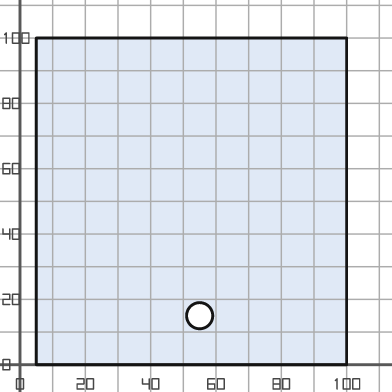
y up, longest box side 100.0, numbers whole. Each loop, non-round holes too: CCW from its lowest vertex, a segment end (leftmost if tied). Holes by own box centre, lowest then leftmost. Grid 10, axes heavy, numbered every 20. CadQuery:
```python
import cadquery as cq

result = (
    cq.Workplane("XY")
    .moveTo(5.0, 0.0)
    .lineTo(100.0, 0.0)
    .lineTo(100.0, 100.0)
    .lineTo(5.0, 100.0)
    .close()
    .moveTo(55.0, 15.0)
    .circle(4.0)
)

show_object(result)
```